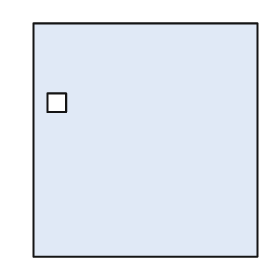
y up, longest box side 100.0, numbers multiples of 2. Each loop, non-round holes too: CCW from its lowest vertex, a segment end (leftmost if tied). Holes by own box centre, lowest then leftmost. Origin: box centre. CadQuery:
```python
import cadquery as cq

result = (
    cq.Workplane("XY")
    .moveTo(-48.0, -50.0)
    .lineTo(48.0, -50.0)
    .lineTo(48.0, 50.0)
    .lineTo(-48.0, 50.0)
    .close()
    .moveTo(-42.0, 12.0)
    .lineTo(-34.0, 12.0)
    .lineTo(-34.0, 20.0)
    .lineTo(-42.0, 20.0)
    .close()
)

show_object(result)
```